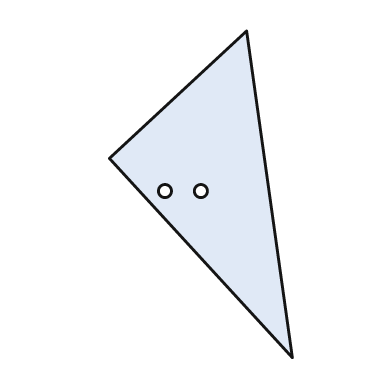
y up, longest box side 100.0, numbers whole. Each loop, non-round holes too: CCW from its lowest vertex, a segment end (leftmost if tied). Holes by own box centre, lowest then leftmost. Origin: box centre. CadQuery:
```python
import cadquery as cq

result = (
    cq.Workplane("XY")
    .moveTo(28.0, -50.0)
    .lineTo(14.0, 50.0)
    .lineTo(-28.0, 11.0)
    .close()
    .moveTo(-11.0, 1.0)
    .circle(2.0)
    .moveTo(0.0, 1.0)
    .circle(2.0)
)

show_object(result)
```